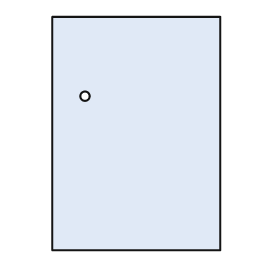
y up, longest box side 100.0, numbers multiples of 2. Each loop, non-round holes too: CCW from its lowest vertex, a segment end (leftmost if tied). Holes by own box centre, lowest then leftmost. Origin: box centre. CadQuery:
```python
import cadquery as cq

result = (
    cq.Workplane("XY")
    .moveTo(-36.0, -50.0)
    .lineTo(36.0, -50.0)
    .lineTo(36.0, 50.0)
    .lineTo(-36.0, 50.0)
    .close()
    .moveTo(-22.0, 16.0)
    .circle(2.0)
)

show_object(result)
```